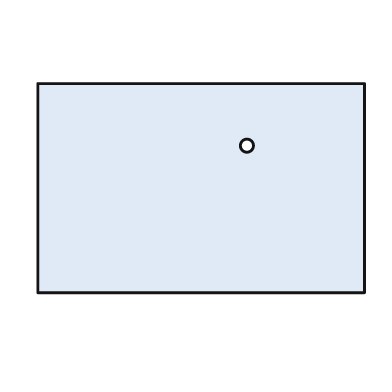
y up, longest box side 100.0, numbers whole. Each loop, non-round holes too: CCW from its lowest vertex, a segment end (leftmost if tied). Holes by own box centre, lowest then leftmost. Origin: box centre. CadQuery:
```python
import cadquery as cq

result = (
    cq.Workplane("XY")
    .moveTo(-50.0, -32.0)
    .lineTo(50.0, -32.0)
    .lineTo(50.0, 32.0)
    .lineTo(-50.0, 32.0)
    .close()
    .moveTo(14.0, 13.0)
    .circle(2.0)
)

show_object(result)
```